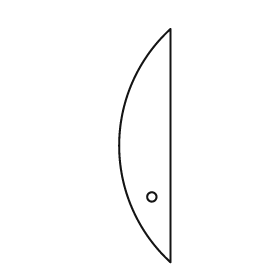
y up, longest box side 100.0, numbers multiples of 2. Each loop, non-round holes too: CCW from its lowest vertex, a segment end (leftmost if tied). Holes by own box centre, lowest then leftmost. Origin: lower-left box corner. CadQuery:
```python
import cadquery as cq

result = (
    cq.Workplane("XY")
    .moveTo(22.0, 0.0)
    .lineTo(22.0, 100.0)
    .threePointArc((0.0, 50.0), (22.0, 0.0))
    .close()
    .moveTo(14.0, 28.0)
    .circle(2.0)
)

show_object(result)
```